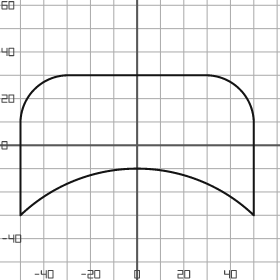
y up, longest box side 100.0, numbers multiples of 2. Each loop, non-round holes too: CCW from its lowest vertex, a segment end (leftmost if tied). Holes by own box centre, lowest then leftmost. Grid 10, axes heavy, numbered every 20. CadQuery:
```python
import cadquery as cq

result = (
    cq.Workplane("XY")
    .moveTo(-50.0, -30.0)
    .threePointArc((0.0, -10.0), (50.0, -30.0))
    .lineTo(50.0, 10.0)
    .threePointArc((44.0, 24.0), (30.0, 30.0))
    .lineTo(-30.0, 30.0)
    .threePointArc((-44.0, 24.0), (-50.0, 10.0))
    .close()
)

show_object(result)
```